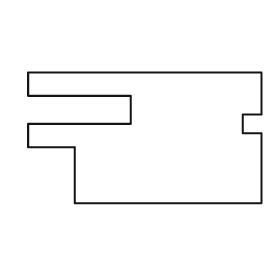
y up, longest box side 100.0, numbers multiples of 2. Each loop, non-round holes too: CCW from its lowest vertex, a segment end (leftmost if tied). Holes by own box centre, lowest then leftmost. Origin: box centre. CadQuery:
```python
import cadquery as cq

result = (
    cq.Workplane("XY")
    .moveTo(-30.0, -28.0)
    .lineTo(50.0, -28.0)
    .lineTo(50.0, 2.0)
    .lineTo(42.0, 2.0)
    .lineTo(42.0, 10.0)
    .lineTo(50.0, 10.0)
    .lineTo(50.0, 28.0)
    .lineTo(-50.0, 28.0)
    .lineTo(-50.0, 18.0)
    .lineTo(-6.0, 18.0)
    .lineTo(-6.0, 6.0)
    .lineTo(-50.0, 6.0)
    .lineTo(-50.0, -4.0)
    .lineTo(-30.0, -4.0)
    .close()
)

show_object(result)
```